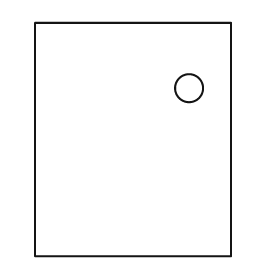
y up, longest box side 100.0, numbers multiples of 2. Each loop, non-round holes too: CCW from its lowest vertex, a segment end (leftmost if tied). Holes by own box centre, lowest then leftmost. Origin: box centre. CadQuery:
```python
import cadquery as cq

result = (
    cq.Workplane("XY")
    .moveTo(-42.0, -50.0)
    .lineTo(42.0, -50.0)
    .lineTo(42.0, 50.0)
    .lineTo(-42.0, 50.0)
    .close()
    .moveTo(24.0, 22.0)
    .circle(6.0)
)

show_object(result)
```